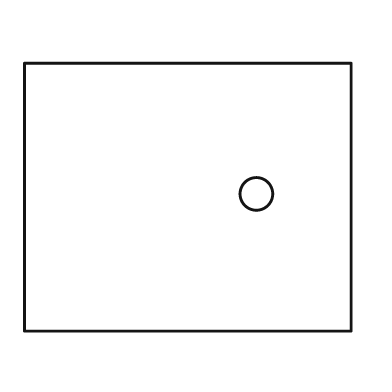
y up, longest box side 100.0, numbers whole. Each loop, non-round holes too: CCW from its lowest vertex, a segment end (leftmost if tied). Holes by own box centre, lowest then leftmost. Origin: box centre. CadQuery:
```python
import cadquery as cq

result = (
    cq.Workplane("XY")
    .moveTo(-50.0, -41.0)
    .lineTo(50.0, -41.0)
    .lineTo(50.0, 41.0)
    .lineTo(-50.0, 41.0)
    .close()
    .moveTo(21.0, 1.0)
    .circle(5.0)
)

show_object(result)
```